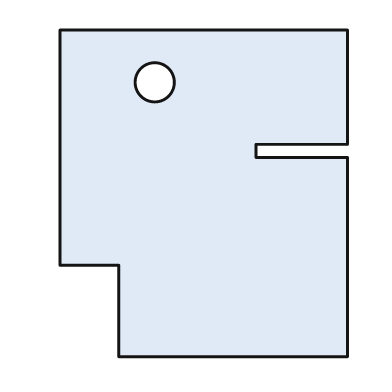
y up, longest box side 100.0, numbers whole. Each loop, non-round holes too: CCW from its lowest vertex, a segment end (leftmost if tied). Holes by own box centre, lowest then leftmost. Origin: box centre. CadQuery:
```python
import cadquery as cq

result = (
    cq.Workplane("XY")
    .moveTo(-26.0, -50.0)
    .lineTo(44.0, -50.0)
    .lineTo(44.0, 11.0)
    .lineTo(16.0, 11.0)
    .lineTo(16.0, 15.0)
    .lineTo(44.0, 15.0)
    .lineTo(44.0, 50.0)
    .lineTo(-44.0, 50.0)
    .lineTo(-44.0, -22.0)
    .lineTo(-26.0, -22.0)
    .close()
    .moveTo(-15.0, 34.0)
    .circle(6.0)
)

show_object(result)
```